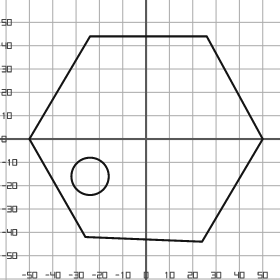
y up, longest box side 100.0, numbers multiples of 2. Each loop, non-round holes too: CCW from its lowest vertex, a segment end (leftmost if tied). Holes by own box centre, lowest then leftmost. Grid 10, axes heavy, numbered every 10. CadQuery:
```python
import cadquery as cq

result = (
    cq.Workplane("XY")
    .moveTo(24.0, -44.0)
    .lineTo(50.0, 0.0)
    .lineTo(26.0, 44.0)
    .lineTo(-24.0, 44.0)
    .lineTo(-50.0, 0.0)
    .lineTo(-26.0, -42.0)
    .close()
    .moveTo(-24.0, -16.0)
    .circle(8.0)
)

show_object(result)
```